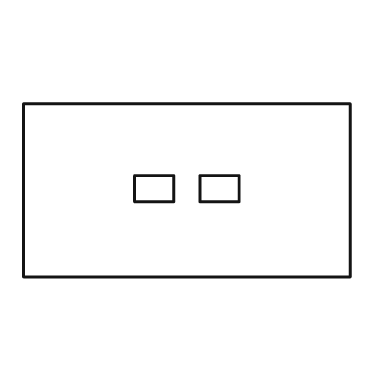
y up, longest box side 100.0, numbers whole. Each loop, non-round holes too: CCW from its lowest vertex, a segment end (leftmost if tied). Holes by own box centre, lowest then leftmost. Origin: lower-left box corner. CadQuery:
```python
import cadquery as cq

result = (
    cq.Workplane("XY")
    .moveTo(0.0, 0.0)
    .lineTo(100.0, 0.0)
    .lineTo(100.0, 53.0)
    .lineTo(0.0, 53.0)
    .close()
    .moveTo(34.0, 23.0)
    .lineTo(46.0, 23.0)
    .lineTo(46.0, 31.0)
    .lineTo(34.0, 31.0)
    .close()
    .moveTo(54.0, 23.0)
    .lineTo(66.0, 23.0)
    .lineTo(66.0, 31.0)
    .lineTo(54.0, 31.0)
    .close()
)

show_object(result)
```